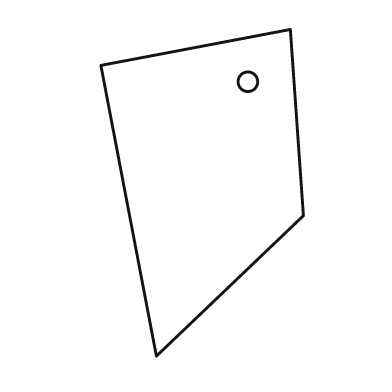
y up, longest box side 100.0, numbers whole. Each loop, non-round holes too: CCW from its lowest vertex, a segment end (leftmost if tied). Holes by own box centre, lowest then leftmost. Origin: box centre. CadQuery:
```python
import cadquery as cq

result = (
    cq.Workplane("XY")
    .moveTo(-14.0, -50.0)
    .lineTo(31.0, -7.0)
    .lineTo(27.0, 50.0)
    .lineTo(-31.0, 39.0)
    .close()
    .moveTo(14.0, 34.0)
    .circle(3.0)
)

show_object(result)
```